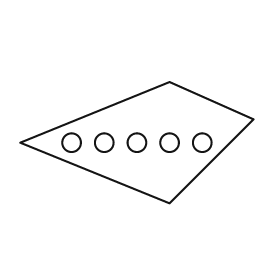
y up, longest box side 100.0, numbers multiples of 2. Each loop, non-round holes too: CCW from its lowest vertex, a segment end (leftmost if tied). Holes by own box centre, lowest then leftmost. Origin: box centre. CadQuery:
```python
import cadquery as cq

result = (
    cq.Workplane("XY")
    .moveTo(14.0, -26.0)
    .lineTo(50.0, 10.0)
    .lineTo(14.0, 26.0)
    .lineTo(-50.0, 0.0)
    .close()
    .moveTo(-28.0, 0.0)
    .circle(4.0)
    .moveTo(-14.0, 0.0)
    .circle(4.0)
    .moveTo(0.0, 0.0)
    .circle(4.0)
    .moveTo(14.0, 0.0)
    .circle(4.0)
    .moveTo(28.0, 0.0)
    .circle(4.0)
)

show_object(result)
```